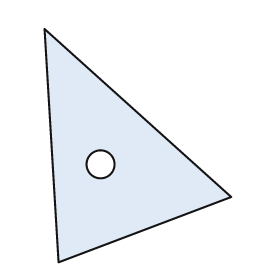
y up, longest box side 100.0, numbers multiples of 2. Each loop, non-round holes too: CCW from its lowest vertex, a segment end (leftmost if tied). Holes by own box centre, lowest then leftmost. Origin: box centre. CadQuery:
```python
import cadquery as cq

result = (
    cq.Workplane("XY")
    .moveTo(-34.0, -50.0)
    .lineTo(40.0, -22.0)
    .lineTo(-40.0, 50.0)
    .close()
    .moveTo(-16.0, -8.0)
    .circle(6.0)
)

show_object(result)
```